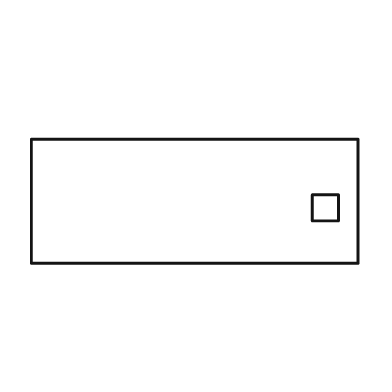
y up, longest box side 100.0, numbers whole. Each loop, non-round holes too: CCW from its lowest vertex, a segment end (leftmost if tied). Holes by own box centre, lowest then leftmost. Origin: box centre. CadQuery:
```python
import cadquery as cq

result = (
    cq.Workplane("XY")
    .moveTo(-50.0, -19.0)
    .lineTo(50.0, -19.0)
    .lineTo(50.0, 19.0)
    .lineTo(-50.0, 19.0)
    .close()
    .moveTo(36.0, -6.0)
    .lineTo(44.0, -6.0)
    .lineTo(44.0, 2.0)
    .lineTo(36.0, 2.0)
    .close()
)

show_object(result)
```